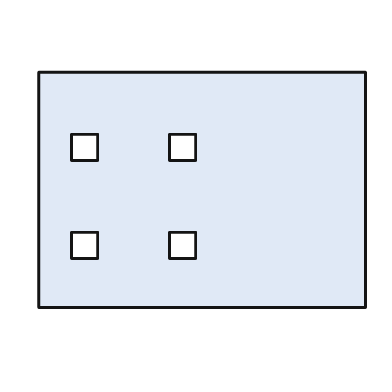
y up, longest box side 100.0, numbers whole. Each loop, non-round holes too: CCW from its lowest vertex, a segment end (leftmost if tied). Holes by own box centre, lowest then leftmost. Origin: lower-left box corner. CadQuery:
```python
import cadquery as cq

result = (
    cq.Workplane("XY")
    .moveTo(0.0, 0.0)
    .lineTo(100.0, 0.0)
    .lineTo(100.0, 72.0)
    .lineTo(0.0, 72.0)
    .close()
    .moveTo(10.0, 15.0)
    .lineTo(18.0, 15.0)
    .lineTo(18.0, 23.0)
    .lineTo(10.0, 23.0)
    .close()
    .moveTo(40.0, 15.0)
    .lineTo(48.0, 15.0)
    .lineTo(48.0, 23.0)
    .lineTo(40.0, 23.0)
    .close()
    .moveTo(10.0, 45.0)
    .lineTo(18.0, 45.0)
    .lineTo(18.0, 53.0)
    .lineTo(10.0, 53.0)
    .close()
    .moveTo(40.0, 45.0)
    .lineTo(48.0, 45.0)
    .lineTo(48.0, 53.0)
    .lineTo(40.0, 53.0)
    .close()
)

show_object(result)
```